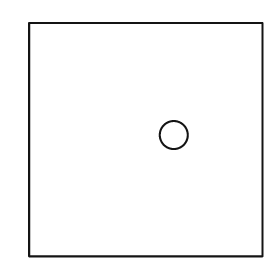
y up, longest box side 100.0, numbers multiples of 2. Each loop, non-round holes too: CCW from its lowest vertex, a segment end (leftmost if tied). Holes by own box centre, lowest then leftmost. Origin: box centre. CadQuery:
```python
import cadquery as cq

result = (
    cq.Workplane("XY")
    .moveTo(-50.0, -50.0)
    .lineTo(50.0, -50.0)
    .lineTo(50.0, 50.0)
    .lineTo(-50.0, 50.0)
    .close()
    .moveTo(12.0, 2.0)
    .circle(6.0)
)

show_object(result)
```